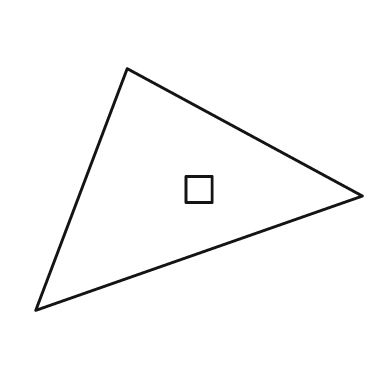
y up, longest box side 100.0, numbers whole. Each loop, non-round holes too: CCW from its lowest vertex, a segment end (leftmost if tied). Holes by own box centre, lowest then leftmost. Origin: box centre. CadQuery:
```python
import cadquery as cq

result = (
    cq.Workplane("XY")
    .moveTo(-50.0, -37.0)
    .lineTo(50.0, -2.0)
    .lineTo(-22.0, 37.0)
    .close()
    .moveTo(-4.0, -4.0)
    .lineTo(4.0, -4.0)
    .lineTo(4.0, 4.0)
    .lineTo(-4.0, 4.0)
    .close()
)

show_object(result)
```